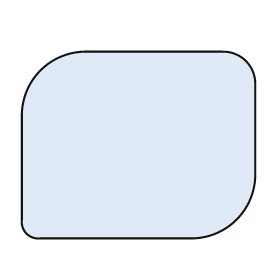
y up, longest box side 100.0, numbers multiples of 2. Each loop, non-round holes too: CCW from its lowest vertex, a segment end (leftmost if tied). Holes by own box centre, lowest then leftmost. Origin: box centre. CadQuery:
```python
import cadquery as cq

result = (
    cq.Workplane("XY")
    .moveTo(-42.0, -40.0)
    .lineTo(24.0, -40.0)
    .threePointArc((42.0, -32.0), (50.0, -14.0))
    .lineTo(50.0, 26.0)
    .threePointArc((46.0, 36.0), (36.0, 40.0))
    .lineTo(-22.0, 40.0)
    .threePointArc((-42.0, 32.0), (-50.0, 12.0))
    .lineTo(-50.0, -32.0)
    .threePointArc((-48.0, -38.0), (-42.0, -40.0))
    .close()
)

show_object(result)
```